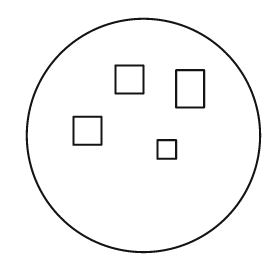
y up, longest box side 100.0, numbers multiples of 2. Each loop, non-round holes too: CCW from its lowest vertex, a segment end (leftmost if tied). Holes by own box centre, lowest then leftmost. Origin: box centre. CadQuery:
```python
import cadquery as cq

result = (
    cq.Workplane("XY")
    .moveTo(0.0, 0.0)
    .circle(50.0)
    .moveTo(6.0, -10.0)
    .lineTo(14.0, -10.0)
    .lineTo(14.0, -2.0)
    .lineTo(6.0, -2.0)
    .close()
    .moveTo(-30.0, -4.0)
    .lineTo(-18.0, -4.0)
    .lineTo(-18.0, 8.0)
    .lineTo(-30.0, 8.0)
    .close()
    .moveTo(14.0, 12.0)
    .lineTo(26.0, 12.0)
    .lineTo(26.0, 28.0)
    .lineTo(14.0, 28.0)
    .close()
    .moveTo(-12.0, 18.0)
    .lineTo(0.0, 18.0)
    .lineTo(0.0, 30.0)
    .lineTo(-12.0, 30.0)
    .close()
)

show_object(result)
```